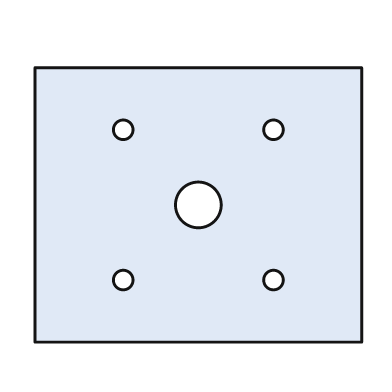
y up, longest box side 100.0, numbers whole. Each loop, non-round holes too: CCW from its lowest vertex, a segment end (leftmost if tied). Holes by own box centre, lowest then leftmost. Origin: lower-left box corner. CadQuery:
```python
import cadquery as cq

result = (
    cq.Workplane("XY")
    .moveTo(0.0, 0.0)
    .lineTo(100.0, 0.0)
    .lineTo(100.0, 84.0)
    .lineTo(0.0, 84.0)
    .close()
    .moveTo(27.0, 19.0)
    .circle(3.0)
    .moveTo(73.0, 19.0)
    .circle(3.0)
    .moveTo(50.0, 42.0)
    .circle(7.0)
    .moveTo(27.0, 65.0)
    .circle(3.0)
    .moveTo(73.0, 65.0)
    .circle(3.0)
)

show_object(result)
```